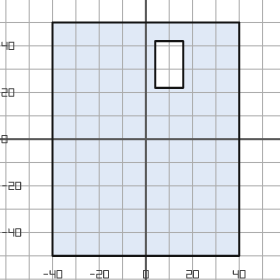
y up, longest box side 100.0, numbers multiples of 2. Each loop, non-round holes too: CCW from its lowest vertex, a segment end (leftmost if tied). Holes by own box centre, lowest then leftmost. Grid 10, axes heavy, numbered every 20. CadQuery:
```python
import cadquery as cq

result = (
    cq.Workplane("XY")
    .moveTo(-40.0, -50.0)
    .lineTo(40.0, -50.0)
    .lineTo(40.0, 50.0)
    .lineTo(-40.0, 50.0)
    .close()
    .moveTo(4.0, 22.0)
    .lineTo(16.0, 22.0)
    .lineTo(16.0, 42.0)
    .lineTo(4.0, 42.0)
    .close()
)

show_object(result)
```